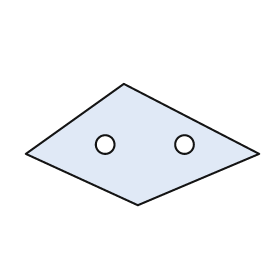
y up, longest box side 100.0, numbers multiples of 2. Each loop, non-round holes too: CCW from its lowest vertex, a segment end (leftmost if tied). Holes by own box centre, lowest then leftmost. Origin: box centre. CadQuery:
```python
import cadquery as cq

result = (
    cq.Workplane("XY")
    .moveTo(-2.0, -26.0)
    .lineTo(50.0, -4.0)
    .lineTo(-8.0, 26.0)
    .lineTo(-50.0, -4.0)
    .close()
    .moveTo(-16.0, 0.0)
    .circle(4.0)
    .moveTo(18.0, 0.0)
    .circle(4.0)
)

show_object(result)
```